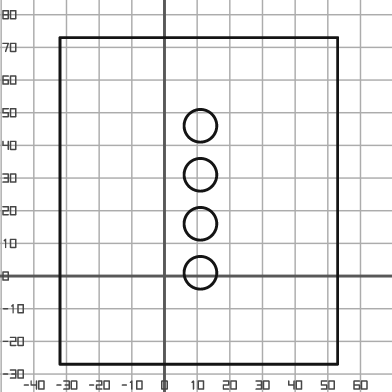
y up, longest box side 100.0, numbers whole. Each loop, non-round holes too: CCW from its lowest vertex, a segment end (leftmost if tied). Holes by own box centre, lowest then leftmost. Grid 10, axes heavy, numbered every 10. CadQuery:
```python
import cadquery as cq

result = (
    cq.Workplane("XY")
    .moveTo(-32.0, -27.0)
    .lineTo(53.0, -27.0)
    .lineTo(53.0, 73.0)
    .lineTo(-32.0, 73.0)
    .close()
    .moveTo(11.0, 1.0)
    .circle(5.0)
    .moveTo(11.0, 16.0)
    .circle(5.0)
    .moveTo(11.0, 31.0)
    .circle(5.0)
    .moveTo(11.0, 46.0)
    .circle(5.0)
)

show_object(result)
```